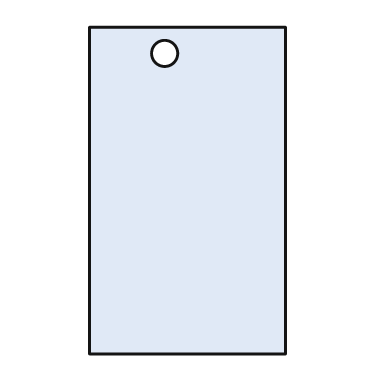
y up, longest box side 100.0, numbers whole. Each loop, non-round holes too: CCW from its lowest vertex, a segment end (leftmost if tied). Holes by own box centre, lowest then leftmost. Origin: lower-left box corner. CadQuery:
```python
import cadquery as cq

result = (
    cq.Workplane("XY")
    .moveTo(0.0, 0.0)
    .lineTo(60.0, 0.0)
    .lineTo(60.0, 100.0)
    .lineTo(0.0, 100.0)
    .close()
    .moveTo(23.0, 92.0)
    .circle(4.0)
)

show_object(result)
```